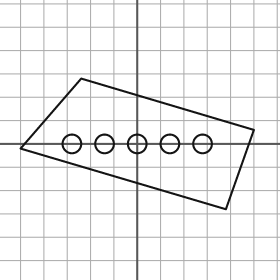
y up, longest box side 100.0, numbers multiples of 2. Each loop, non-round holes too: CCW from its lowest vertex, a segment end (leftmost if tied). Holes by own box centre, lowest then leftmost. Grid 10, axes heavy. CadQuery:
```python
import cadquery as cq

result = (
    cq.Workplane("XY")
    .moveTo(38.0, -28.0)
    .lineTo(50.0, 6.0)
    .lineTo(-24.0, 28.0)
    .lineTo(-50.0, -2.0)
    .close()
    .moveTo(-28.0, 0.0)
    .circle(4.0)
    .moveTo(-14.0, 0.0)
    .circle(4.0)
    .moveTo(0.0, 0.0)
    .circle(4.0)
    .moveTo(14.0, 0.0)
    .circle(4.0)
    .moveTo(28.0, 0.0)
    .circle(4.0)
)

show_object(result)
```